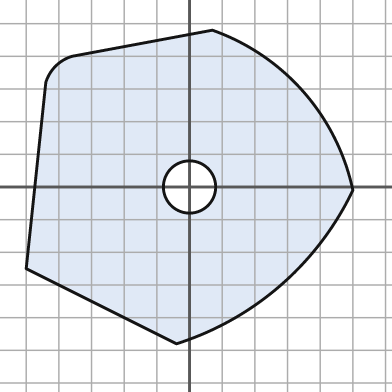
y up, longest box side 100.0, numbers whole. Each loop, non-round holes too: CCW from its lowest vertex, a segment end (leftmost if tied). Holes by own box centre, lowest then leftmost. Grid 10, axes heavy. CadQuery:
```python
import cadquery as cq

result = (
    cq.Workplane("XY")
    .moveTo(-4.0, -48.0)
    .threePointArc((28.0, -30.0), (50.0, -1.0))
    .threePointArc((35.0, 29.0), (7.0, 48.0))
    .lineTo(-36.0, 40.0)
    .threePointArc((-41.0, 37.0), (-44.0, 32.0))
    .lineTo(-50.0, -25.0)
    .close()
    .moveTo(0.0, 0.0)
    .circle(8.0)
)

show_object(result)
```